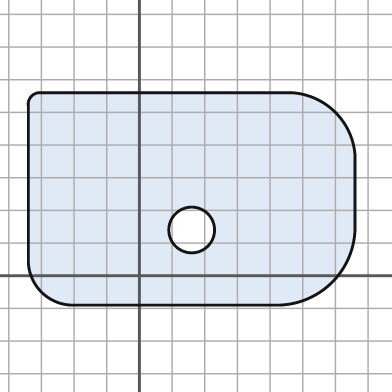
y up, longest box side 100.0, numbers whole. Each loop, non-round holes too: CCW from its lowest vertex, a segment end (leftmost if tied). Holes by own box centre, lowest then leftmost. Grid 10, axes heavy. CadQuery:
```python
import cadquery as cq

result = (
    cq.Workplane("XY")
    .moveTo(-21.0, -9.0)
    .lineTo(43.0, -9.0)
    .threePointArc((59.0, -2.0), (66.0, 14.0))
    .lineTo(66.0, 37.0)
    .threePointArc((60.0, 50.0), (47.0, 56.0))
    .lineTo(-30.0, 56.0)
    .threePointArc((-33.0, 55.0), (-34.0, 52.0))
    .lineTo(-34.0, 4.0)
    .threePointArc((-30.0, -5.0), (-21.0, -9.0))
    .close()
    .moveTo(16.0, 14.0)
    .circle(7.0)
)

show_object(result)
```